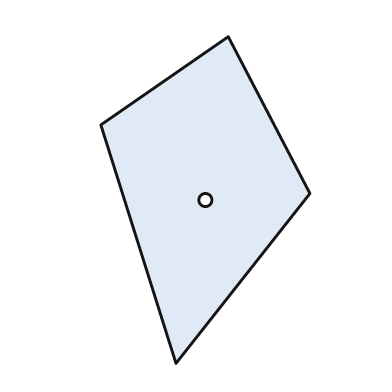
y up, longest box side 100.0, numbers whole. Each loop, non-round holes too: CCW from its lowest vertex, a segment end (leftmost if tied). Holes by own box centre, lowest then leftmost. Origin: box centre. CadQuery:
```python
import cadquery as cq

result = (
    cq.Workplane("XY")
    .moveTo(-9.0, -50.0)
    .lineTo(32.0, 2.0)
    .lineTo(7.0, 50.0)
    .lineTo(-32.0, 23.0)
    .close()
    .moveTo(0.0, 0.0)
    .circle(2.0)
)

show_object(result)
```